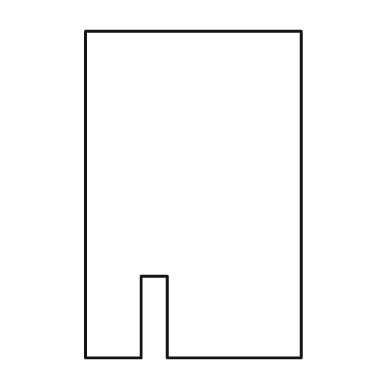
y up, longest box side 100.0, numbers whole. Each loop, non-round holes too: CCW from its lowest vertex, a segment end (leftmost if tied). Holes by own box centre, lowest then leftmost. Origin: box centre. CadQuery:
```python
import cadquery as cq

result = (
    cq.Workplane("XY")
    .moveTo(-33.0, -50.0)
    .lineTo(-16.0, -50.0)
    .lineTo(-16.0, -25.0)
    .lineTo(-8.0, -25.0)
    .lineTo(-8.0, -50.0)
    .lineTo(33.0, -50.0)
    .lineTo(33.0, 50.0)
    .lineTo(-33.0, 50.0)
    .close()
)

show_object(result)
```